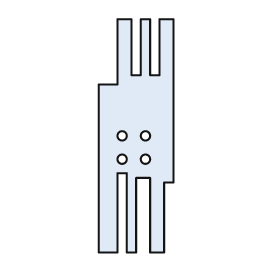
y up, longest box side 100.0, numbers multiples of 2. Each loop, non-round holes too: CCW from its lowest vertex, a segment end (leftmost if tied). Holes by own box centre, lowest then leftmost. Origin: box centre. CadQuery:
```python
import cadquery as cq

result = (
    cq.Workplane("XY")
    .moveTo(-16.0, -50.0)
    .lineTo(-8.0, -50.0)
    .lineTo(-8.0, -16.0)
    .lineTo(-4.0, -16.0)
    .lineTo(-4.0, -50.0)
    .lineTo(0.0, -50.0)
    .lineTo(0.0, -18.0)
    .lineTo(6.0, -18.0)
    .lineTo(6.0, -50.0)
    .lineTo(12.0, -50.0)
    .lineTo(12.0, -20.0)
    .lineTo(16.0, -20.0)
    .lineTo(16.0, 50.0)
    .lineTo(10.0, 50.0)
    .lineTo(10.0, 26.0)
    .lineTo(6.0, 26.0)
    .lineTo(6.0, 50.0)
    .lineTo(2.0, 50.0)
    .lineTo(2.0, 26.0)
    .lineTo(-2.0, 26.0)
    .lineTo(-2.0, 50.0)
    .lineTo(-8.0, 50.0)
    .lineTo(-8.0, 22.0)
    .lineTo(-16.0, 22.0)
    .close()
    .moveTo(-6.0, -10.0)
    .circle(2.0)
    .moveTo(4.0, -10.0)
    .circle(2.0)
    .moveTo(-6.0, 0.0)
    .circle(2.0)
    .moveTo(4.0, 0.0)
    .circle(2.0)
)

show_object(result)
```